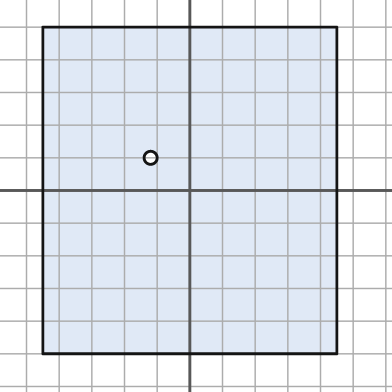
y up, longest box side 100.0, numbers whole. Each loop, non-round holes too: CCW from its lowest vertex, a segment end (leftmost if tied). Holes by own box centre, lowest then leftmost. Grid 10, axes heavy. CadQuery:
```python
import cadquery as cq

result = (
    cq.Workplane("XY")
    .moveTo(-45.0, -50.0)
    .lineTo(45.0, -50.0)
    .lineTo(45.0, 50.0)
    .lineTo(-45.0, 50.0)
    .close()
    .moveTo(-12.0, 10.0)
    .circle(2.0)
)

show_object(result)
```